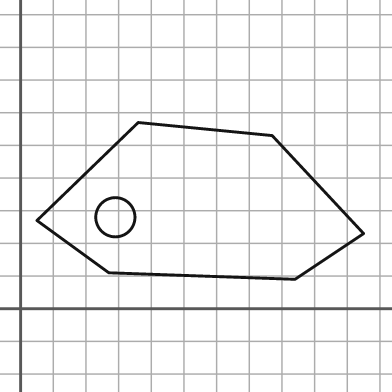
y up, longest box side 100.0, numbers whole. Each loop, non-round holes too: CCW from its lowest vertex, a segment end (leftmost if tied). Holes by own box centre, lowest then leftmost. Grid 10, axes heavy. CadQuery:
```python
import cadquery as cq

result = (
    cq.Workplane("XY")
    .moveTo(84.0, 9.0)
    .lineTo(105.0, 23.0)
    .lineTo(77.0, 53.0)
    .lineTo(36.0, 57.0)
    .lineTo(5.0, 27.0)
    .lineTo(27.0, 11.0)
    .close()
    .moveTo(29.0, 28.0)
    .circle(6.0)
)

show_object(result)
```